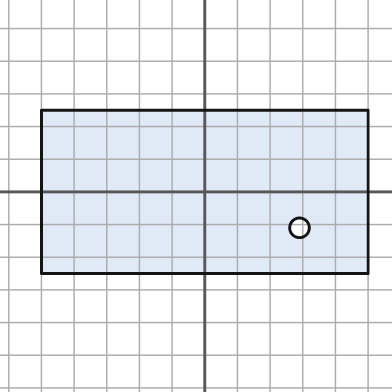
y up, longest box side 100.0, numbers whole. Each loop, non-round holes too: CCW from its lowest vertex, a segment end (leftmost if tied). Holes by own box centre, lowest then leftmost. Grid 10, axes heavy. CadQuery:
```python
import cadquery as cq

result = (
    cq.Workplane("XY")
    .moveTo(-50.0, -25.0)
    .lineTo(50.0, -25.0)
    .lineTo(50.0, 25.0)
    .lineTo(-50.0, 25.0)
    .close()
    .moveTo(29.0, -11.0)
    .circle(3.0)
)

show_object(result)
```